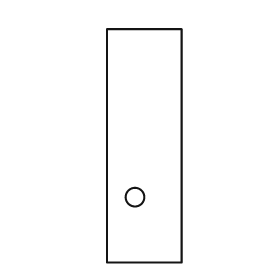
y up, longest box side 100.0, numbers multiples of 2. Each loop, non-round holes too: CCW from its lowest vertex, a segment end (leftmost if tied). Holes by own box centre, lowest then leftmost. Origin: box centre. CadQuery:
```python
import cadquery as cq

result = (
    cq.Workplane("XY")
    .moveTo(-16.0, -50.0)
    .lineTo(16.0, -50.0)
    .lineTo(16.0, 50.0)
    .lineTo(-16.0, 50.0)
    .close()
    .moveTo(-4.0, -22.0)
    .circle(4.0)
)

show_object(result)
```